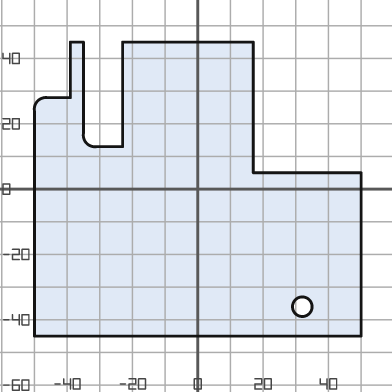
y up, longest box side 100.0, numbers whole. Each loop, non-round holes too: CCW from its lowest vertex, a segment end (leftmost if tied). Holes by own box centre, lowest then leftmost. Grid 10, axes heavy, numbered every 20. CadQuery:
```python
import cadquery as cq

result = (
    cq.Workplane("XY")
    .moveTo(-50.0, -45.0)
    .lineTo(50.0, -45.0)
    .lineTo(50.0, 5.0)
    .lineTo(17.0, 5.0)
    .lineTo(17.0, 45.0)
    .lineTo(-23.0, 45.0)
    .lineTo(-23.0, 13.0)
    .lineTo(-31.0, 13.0)
    .threePointArc((-34.0, 14.0), (-35.0, 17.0))
    .lineTo(-35.0, 45.0)
    .lineTo(-39.0, 45.0)
    .lineTo(-39.0, 28.0)
    .lineTo(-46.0, 28.0)
    .threePointArc((-49.0, 27.0), (-50.0, 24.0))
    .close()
    .moveTo(32.0, -36.0)
    .circle(3.0)
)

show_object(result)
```